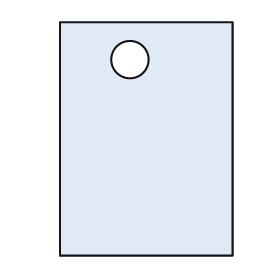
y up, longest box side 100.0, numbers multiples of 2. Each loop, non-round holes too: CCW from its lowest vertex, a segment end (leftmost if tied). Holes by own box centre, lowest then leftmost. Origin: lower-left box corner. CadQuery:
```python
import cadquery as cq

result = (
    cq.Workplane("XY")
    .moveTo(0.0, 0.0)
    .lineTo(74.0, 0.0)
    .lineTo(74.0, 100.0)
    .lineTo(0.0, 100.0)
    .close()
    .moveTo(30.0, 84.0)
    .circle(8.0)
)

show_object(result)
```